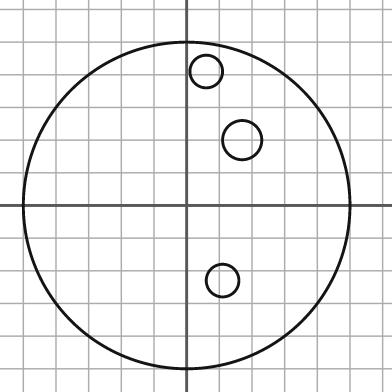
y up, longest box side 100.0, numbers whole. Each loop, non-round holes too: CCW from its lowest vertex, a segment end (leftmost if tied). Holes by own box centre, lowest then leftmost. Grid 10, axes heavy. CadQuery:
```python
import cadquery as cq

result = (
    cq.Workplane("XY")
    .moveTo(0.0, 0.0)
    .circle(50.0)
    .moveTo(11.0, -23.0)
    .circle(5.0)
    .moveTo(17.0, 20.0)
    .circle(6.0)
    .moveTo(6.0, 41.0)
    .circle(5.0)
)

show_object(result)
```